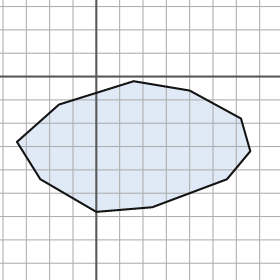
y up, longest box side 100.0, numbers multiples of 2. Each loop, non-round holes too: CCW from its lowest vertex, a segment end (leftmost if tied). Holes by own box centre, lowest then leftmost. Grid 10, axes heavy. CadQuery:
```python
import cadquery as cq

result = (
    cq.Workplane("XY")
    .moveTo(0.0, -58.0)
    .lineTo(24.0, -56.0)
    .lineTo(56.0, -44.0)
    .lineTo(66.0, -32.0)
    .lineTo(62.0, -18.0)
    .lineTo(40.0, -6.0)
    .lineTo(16.0, -2.0)
    .lineTo(-16.0, -12.0)
    .lineTo(-34.0, -28.0)
    .lineTo(-24.0, -44.0)
    .close()
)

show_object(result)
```